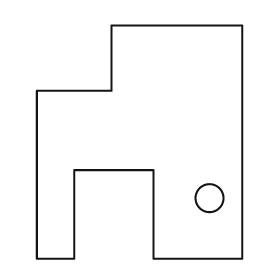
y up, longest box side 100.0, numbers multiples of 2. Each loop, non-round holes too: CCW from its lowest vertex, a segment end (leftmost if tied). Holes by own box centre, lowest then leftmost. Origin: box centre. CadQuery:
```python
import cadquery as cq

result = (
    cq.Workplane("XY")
    .moveTo(-44.0, -50.0)
    .lineTo(-28.0, -50.0)
    .lineTo(-28.0, -12.0)
    .lineTo(6.0, -12.0)
    .lineTo(6.0, -50.0)
    .lineTo(44.0, -50.0)
    .lineTo(44.0, 50.0)
    .lineTo(-12.0, 50.0)
    .lineTo(-12.0, 22.0)
    .lineTo(-44.0, 22.0)
    .close()
    .moveTo(30.0, -24.0)
    .circle(6.0)
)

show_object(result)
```